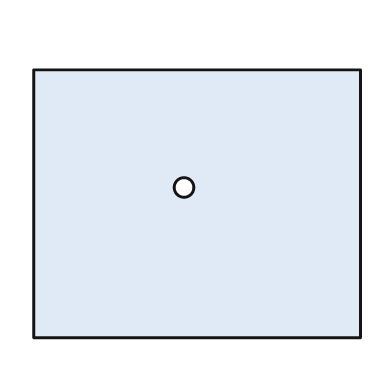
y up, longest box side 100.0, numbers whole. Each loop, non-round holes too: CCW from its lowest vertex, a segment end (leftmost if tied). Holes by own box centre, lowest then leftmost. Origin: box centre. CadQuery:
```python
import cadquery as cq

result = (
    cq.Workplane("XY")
    .moveTo(-50.0, -41.0)
    .lineTo(50.0, -41.0)
    .lineTo(50.0, 41.0)
    .lineTo(-50.0, 41.0)
    .close()
    .moveTo(-4.0, 5.0)
    .circle(3.0)
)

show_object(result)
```